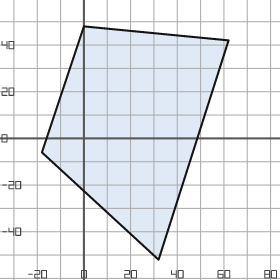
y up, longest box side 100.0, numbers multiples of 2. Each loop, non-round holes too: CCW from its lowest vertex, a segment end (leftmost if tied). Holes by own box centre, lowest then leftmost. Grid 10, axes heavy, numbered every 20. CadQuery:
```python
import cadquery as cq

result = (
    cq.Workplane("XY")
    .moveTo(32.0, -52.0)
    .lineTo(62.0, 42.0)
    .lineTo(0.0, 48.0)
    .lineTo(-18.0, -6.0)
    .close()
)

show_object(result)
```